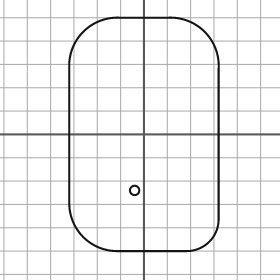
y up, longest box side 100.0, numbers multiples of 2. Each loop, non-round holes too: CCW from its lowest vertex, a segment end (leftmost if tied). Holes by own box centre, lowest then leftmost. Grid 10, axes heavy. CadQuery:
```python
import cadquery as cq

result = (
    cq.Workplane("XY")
    .moveTo(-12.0, -50.0)
    .lineTo(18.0, -50.0)
    .threePointArc((28.0, -46.0), (32.0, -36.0))
    .lineTo(32.0, 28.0)
    .threePointArc((26.0, 44.0), (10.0, 50.0))
    .lineTo(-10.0, 50.0)
    .threePointArc((-26.0, 44.0), (-32.0, 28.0))
    .lineTo(-32.0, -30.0)
    .threePointArc((-26.0, -44.0), (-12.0, -50.0))
    .close()
    .moveTo(-4.0, -24.0)
    .circle(2.0)
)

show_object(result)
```